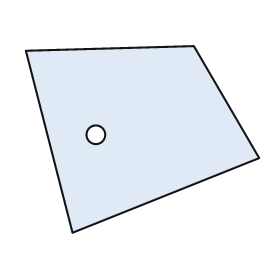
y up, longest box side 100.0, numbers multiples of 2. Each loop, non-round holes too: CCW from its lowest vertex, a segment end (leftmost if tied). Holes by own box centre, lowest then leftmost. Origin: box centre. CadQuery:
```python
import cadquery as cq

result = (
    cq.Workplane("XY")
    .moveTo(-30.0, -40.0)
    .lineTo(50.0, -8.0)
    .lineTo(22.0, 40.0)
    .lineTo(-50.0, 38.0)
    .close()
    .moveTo(-20.0, 2.0)
    .circle(4.0)
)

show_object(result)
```